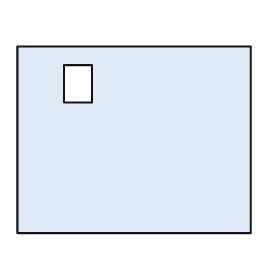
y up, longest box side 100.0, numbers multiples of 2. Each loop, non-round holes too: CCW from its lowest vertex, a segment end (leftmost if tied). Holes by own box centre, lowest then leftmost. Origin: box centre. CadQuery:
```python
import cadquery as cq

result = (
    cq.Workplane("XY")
    .moveTo(-50.0, -40.0)
    .lineTo(50.0, -40.0)
    .lineTo(50.0, 40.0)
    .lineTo(-50.0, 40.0)
    .close()
    .moveTo(-30.0, 16.0)
    .lineTo(-18.0, 16.0)
    .lineTo(-18.0, 32.0)
    .lineTo(-30.0, 32.0)
    .close()
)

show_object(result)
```